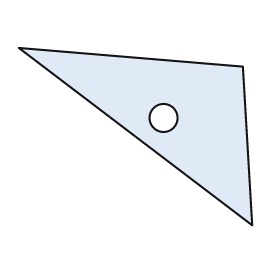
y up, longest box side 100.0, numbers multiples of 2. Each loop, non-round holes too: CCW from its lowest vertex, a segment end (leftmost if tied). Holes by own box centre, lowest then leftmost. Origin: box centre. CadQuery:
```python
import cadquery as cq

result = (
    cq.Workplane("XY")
    .moveTo(50.0, -38.0)
    .lineTo(46.0, 30.0)
    .lineTo(-50.0, 38.0)
    .close()
    .moveTo(12.0, 8.0)
    .circle(6.0)
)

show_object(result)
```